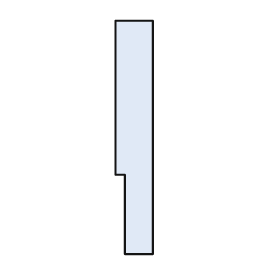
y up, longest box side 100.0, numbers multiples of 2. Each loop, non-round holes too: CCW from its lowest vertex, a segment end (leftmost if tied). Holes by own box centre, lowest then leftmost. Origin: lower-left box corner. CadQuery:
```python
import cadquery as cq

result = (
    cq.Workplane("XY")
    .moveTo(4.0, 0.0)
    .lineTo(16.0, 0.0)
    .lineTo(16.0, 100.0)
    .lineTo(0.0, 100.0)
    .lineTo(0.0, 34.0)
    .lineTo(4.0, 34.0)
    .close()
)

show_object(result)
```